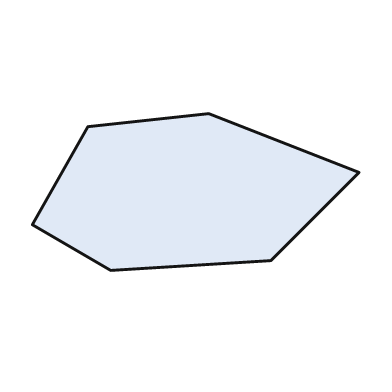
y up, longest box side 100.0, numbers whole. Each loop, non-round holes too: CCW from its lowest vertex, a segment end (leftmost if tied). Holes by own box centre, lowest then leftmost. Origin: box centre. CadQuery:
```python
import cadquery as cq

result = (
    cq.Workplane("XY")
    .moveTo(-26.0, -24.0)
    .lineTo(23.0, -21.0)
    .lineTo(50.0, 6.0)
    .lineTo(4.0, 24.0)
    .lineTo(-33.0, 20.0)
    .lineTo(-50.0, -10.0)
    .close()
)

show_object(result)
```